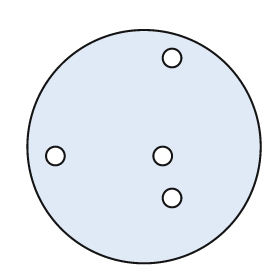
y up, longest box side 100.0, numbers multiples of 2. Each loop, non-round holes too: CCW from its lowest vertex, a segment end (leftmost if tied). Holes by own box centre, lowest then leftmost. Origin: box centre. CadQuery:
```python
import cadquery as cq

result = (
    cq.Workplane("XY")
    .moveTo(0.0, 0.0)
    .circle(50.0)
    .moveTo(12.0, -22.0)
    .circle(4.0)
    .moveTo(-38.0, -4.0)
    .circle(4.0)
    .moveTo(8.0, -4.0)
    .circle(4.0)
    .moveTo(12.0, 38.0)
    .circle(4.0)
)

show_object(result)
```